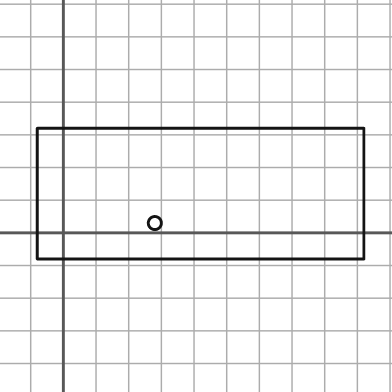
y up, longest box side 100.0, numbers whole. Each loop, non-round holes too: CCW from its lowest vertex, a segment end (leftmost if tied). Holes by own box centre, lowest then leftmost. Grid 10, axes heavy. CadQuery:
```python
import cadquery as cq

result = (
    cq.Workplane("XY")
    .moveTo(-8.0, -8.0)
    .lineTo(92.0, -8.0)
    .lineTo(92.0, 32.0)
    .lineTo(-8.0, 32.0)
    .close()
    .moveTo(28.0, 3.0)
    .circle(2.0)
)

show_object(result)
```